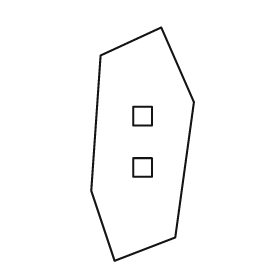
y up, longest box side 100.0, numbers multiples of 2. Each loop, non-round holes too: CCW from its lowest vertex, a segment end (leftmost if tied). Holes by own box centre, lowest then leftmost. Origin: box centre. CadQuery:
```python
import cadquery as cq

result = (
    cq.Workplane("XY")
    .moveTo(-12.0, -50.0)
    .lineTo(14.0, -40.0)
    .lineTo(22.0, 18.0)
    .lineTo(8.0, 50.0)
    .lineTo(-18.0, 38.0)
    .lineTo(-22.0, -20.0)
    .close()
    .moveTo(-4.0, -14.0)
    .lineTo(4.0, -14.0)
    .lineTo(4.0, -6.0)
    .lineTo(-4.0, -6.0)
    .close()
    .moveTo(-4.0, 8.0)
    .lineTo(4.0, 8.0)
    .lineTo(4.0, 16.0)
    .lineTo(-4.0, 16.0)
    .close()
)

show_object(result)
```